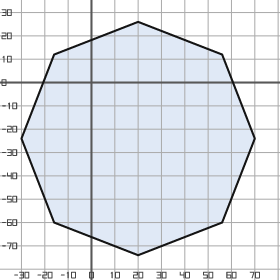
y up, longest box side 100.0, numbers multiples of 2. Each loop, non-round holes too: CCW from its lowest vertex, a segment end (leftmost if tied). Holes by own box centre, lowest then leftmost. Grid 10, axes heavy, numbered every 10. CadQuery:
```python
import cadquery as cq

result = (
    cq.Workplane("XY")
    .moveTo(20.0, -74.0)
    .lineTo(56.0, -60.0)
    .lineTo(70.0, -24.0)
    .lineTo(56.0, 12.0)
    .lineTo(20.0, 26.0)
    .lineTo(-16.0, 12.0)
    .lineTo(-30.0, -24.0)
    .lineTo(-16.0, -60.0)
    .close()
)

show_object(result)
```